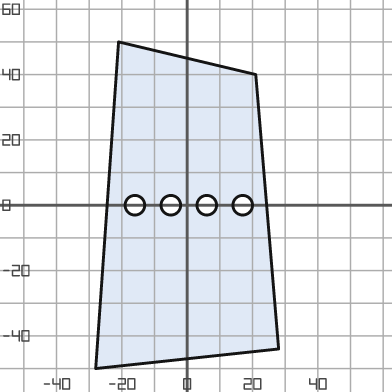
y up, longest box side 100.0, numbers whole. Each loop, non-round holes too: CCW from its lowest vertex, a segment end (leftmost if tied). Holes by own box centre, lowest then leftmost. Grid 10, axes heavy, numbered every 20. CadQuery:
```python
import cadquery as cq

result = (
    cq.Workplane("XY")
    .moveTo(-28.0, -50.0)
    .lineTo(28.0, -44.0)
    .lineTo(21.0, 40.0)
    .lineTo(-21.0, 50.0)
    .close()
    .moveTo(-16.0, 0.0)
    .circle(3.0)
    .moveTo(-5.0, 0.0)
    .circle(3.0)
    .moveTo(6.0, 0.0)
    .circle(3.0)
    .moveTo(17.0, 0.0)
    .circle(3.0)
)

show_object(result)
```